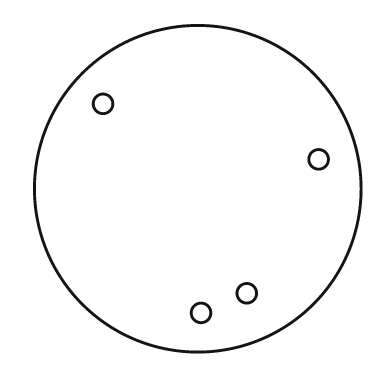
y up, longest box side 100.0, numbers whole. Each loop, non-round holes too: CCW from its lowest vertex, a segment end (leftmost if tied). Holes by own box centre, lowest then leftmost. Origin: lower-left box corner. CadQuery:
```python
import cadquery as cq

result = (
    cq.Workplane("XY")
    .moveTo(50.0, 50.0)
    .circle(50.0)
    .moveTo(51.0, 12.0)
    .circle(3.0)
    .moveTo(65.0, 18.0)
    .circle(3.0)
    .moveTo(87.0, 59.0)
    .circle(3.0)
    .moveTo(21.0, 76.0)
    .circle(3.0)
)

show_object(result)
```